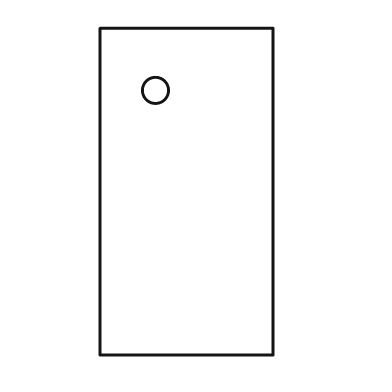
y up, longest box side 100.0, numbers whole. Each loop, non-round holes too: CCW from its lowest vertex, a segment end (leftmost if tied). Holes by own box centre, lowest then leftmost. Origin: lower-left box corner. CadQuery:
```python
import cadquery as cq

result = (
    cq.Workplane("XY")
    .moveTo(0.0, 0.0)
    .lineTo(53.0, 0.0)
    .lineTo(53.0, 100.0)
    .lineTo(0.0, 100.0)
    .close()
    .moveTo(17.0, 81.0)
    .circle(4.0)
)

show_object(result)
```